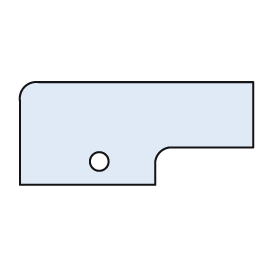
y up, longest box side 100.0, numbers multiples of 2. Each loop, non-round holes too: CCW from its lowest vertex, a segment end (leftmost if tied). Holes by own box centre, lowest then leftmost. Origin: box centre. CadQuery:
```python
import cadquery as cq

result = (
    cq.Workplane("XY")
    .moveTo(-50.0, -22.0)
    .lineTo(8.0, -22.0)
    .lineTo(8.0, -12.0)
    .threePointArc((10.0, -8.0), (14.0, -6.0))
    .lineTo(50.0, -6.0)
    .lineTo(50.0, 22.0)
    .lineTo(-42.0, 22.0)
    .threePointArc((-48.0, 20.0), (-50.0, 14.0))
    .close()
    .moveTo(-16.0, -12.0)
    .circle(4.0)
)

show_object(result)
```